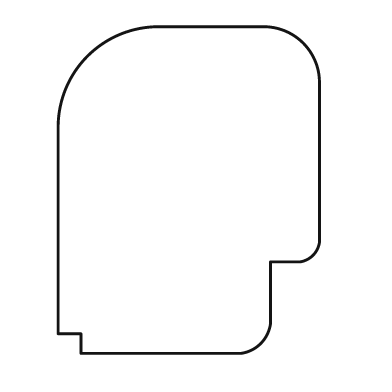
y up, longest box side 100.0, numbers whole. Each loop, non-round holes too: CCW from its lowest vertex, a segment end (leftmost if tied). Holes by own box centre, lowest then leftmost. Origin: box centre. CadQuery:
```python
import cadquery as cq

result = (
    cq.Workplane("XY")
    .moveTo(-33.0, -50.0)
    .lineTo(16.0, -50.0)
    .threePointArc((22.0, -47.0), (25.0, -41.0))
    .lineTo(25.0, -22.0)
    .lineTo(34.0, -22.0)
    .threePointArc((38.0, -20.0), (40.0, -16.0))
    .lineTo(40.0, 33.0)
    .threePointArc((35.0, 45.0), (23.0, 50.0))
    .lineTo(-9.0, 50.0)
    .threePointArc((-31.0, 41.0), (-40.0, 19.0))
    .lineTo(-40.0, -44.0)
    .lineTo(-33.0, -44.0)
    .close()
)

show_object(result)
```